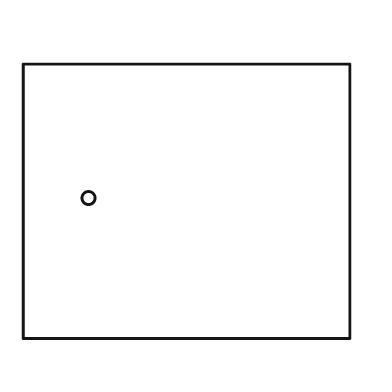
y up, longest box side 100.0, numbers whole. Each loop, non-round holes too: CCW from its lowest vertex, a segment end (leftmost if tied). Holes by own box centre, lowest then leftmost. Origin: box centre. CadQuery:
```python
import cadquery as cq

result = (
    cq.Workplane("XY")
    .moveTo(-50.0, -42.0)
    .lineTo(50.0, -42.0)
    .lineTo(50.0, 42.0)
    .lineTo(-50.0, 42.0)
    .close()
    .moveTo(-30.0, 1.0)
    .circle(2.0)
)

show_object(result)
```